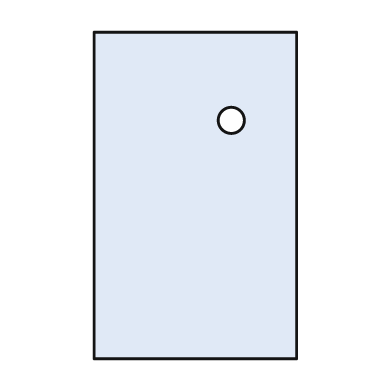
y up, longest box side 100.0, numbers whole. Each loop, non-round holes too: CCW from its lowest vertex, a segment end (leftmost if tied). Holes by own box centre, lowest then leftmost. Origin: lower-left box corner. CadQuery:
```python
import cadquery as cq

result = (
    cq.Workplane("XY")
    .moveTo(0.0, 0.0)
    .lineTo(62.0, 0.0)
    .lineTo(62.0, 100.0)
    .lineTo(0.0, 100.0)
    .close()
    .moveTo(42.0, 73.0)
    .circle(4.0)
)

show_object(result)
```